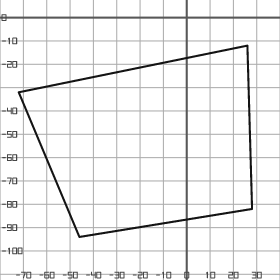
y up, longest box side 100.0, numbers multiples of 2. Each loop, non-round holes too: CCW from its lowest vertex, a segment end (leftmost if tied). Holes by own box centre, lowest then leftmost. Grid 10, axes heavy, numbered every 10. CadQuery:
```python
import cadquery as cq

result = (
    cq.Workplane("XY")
    .moveTo(-46.0, -94.0)
    .lineTo(28.0, -82.0)
    .lineTo(26.0, -12.0)
    .lineTo(-72.0, -32.0)
    .close()
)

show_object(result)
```